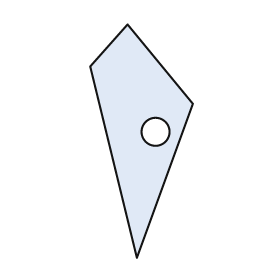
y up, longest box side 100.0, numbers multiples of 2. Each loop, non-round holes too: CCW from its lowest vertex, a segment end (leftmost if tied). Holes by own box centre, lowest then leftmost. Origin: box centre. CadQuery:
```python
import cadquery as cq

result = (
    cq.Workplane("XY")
    .moveTo(-2.0, -50.0)
    .lineTo(22.0, 16.0)
    .lineTo(-6.0, 50.0)
    .lineTo(-22.0, 32.0)
    .close()
    .moveTo(6.0, 4.0)
    .circle(6.0)
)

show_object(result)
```